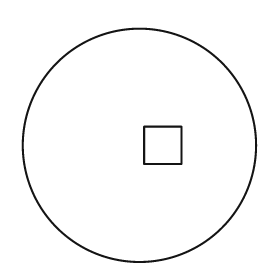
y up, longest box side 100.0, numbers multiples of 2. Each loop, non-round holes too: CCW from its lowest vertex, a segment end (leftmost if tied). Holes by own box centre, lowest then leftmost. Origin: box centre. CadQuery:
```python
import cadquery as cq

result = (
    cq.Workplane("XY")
    .moveTo(0.0, 0.0)
    .circle(50.0)
    .moveTo(2.0, -8.0)
    .lineTo(18.0, -8.0)
    .lineTo(18.0, 8.0)
    .lineTo(2.0, 8.0)
    .close()
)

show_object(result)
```